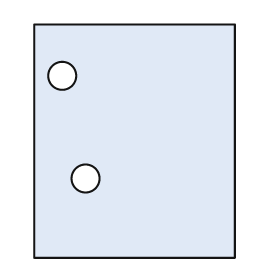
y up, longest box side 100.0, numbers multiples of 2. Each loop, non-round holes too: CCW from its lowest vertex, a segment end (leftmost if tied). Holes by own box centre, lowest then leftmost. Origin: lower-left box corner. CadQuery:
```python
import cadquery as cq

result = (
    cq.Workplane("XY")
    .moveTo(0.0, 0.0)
    .lineTo(86.0, 0.0)
    .lineTo(86.0, 100.0)
    .lineTo(0.0, 100.0)
    .close()
    .moveTo(22.0, 34.0)
    .circle(6.0)
    .moveTo(12.0, 78.0)
    .circle(6.0)
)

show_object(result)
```